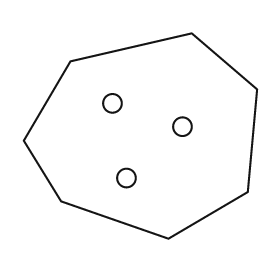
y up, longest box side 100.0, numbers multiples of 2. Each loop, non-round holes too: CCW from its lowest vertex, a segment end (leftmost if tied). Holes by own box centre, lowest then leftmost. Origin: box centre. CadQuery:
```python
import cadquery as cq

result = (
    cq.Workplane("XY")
    .moveTo(12.0, -44.0)
    .lineTo(46.0, -24.0)
    .lineTo(50.0, 20.0)
    .lineTo(22.0, 44.0)
    .lineTo(-30.0, 32.0)
    .lineTo(-50.0, -2.0)
    .lineTo(-34.0, -28.0)
    .close()
    .moveTo(-6.0, -18.0)
    .circle(4.0)
    .moveTo(18.0, 4.0)
    .circle(4.0)
    .moveTo(-12.0, 14.0)
    .circle(4.0)
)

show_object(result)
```